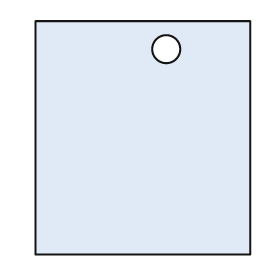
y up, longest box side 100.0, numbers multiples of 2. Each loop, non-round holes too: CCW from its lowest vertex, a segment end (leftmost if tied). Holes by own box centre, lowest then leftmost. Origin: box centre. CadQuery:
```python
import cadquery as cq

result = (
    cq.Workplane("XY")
    .moveTo(-46.0, -50.0)
    .lineTo(46.0, -50.0)
    .lineTo(46.0, 50.0)
    .lineTo(-46.0, 50.0)
    .close()
    .moveTo(10.0, 38.0)
    .circle(6.0)
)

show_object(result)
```